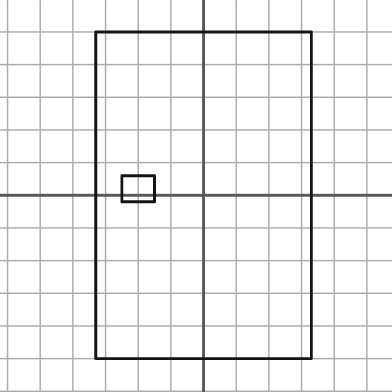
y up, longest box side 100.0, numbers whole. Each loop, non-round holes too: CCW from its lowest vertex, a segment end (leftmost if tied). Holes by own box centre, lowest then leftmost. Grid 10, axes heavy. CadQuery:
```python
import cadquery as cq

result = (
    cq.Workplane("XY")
    .moveTo(-33.0, -50.0)
    .lineTo(33.0, -50.0)
    .lineTo(33.0, 50.0)
    .lineTo(-33.0, 50.0)
    .close()
    .moveTo(-25.0, -2.0)
    .lineTo(-15.0, -2.0)
    .lineTo(-15.0, 6.0)
    .lineTo(-25.0, 6.0)
    .close()
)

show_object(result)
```